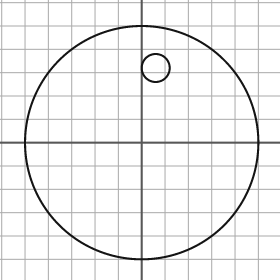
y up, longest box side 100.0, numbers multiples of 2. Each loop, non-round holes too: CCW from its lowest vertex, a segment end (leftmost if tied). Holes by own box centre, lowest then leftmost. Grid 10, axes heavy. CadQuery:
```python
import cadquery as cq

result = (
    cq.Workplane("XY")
    .moveTo(0.0, 0.0)
    .circle(50.0)
    .moveTo(6.0, 32.0)
    .circle(6.0)
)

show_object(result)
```